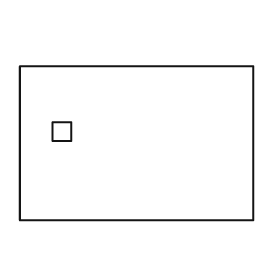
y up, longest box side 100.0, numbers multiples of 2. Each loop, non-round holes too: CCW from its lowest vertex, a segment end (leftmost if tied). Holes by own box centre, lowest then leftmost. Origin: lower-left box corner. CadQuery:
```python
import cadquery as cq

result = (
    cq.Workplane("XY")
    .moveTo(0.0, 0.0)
    .lineTo(100.0, 0.0)
    .lineTo(100.0, 66.0)
    .lineTo(0.0, 66.0)
    .close()
    .moveTo(14.0, 34.0)
    .lineTo(22.0, 34.0)
    .lineTo(22.0, 42.0)
    .lineTo(14.0, 42.0)
    .close()
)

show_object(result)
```